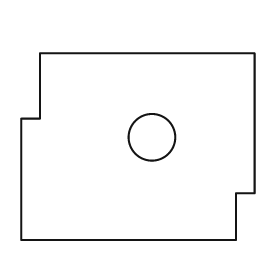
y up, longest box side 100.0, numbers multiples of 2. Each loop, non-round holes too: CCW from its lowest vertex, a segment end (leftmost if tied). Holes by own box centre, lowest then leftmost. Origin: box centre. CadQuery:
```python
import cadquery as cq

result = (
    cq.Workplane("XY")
    .moveTo(-50.0, -40.0)
    .lineTo(42.0, -40.0)
    .lineTo(42.0, -20.0)
    .lineTo(50.0, -20.0)
    .lineTo(50.0, 40.0)
    .lineTo(-42.0, 40.0)
    .lineTo(-42.0, 12.0)
    .lineTo(-50.0, 12.0)
    .close()
    .moveTo(6.0, 4.0)
    .circle(10.0)
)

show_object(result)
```